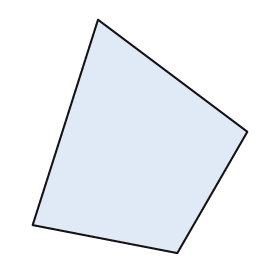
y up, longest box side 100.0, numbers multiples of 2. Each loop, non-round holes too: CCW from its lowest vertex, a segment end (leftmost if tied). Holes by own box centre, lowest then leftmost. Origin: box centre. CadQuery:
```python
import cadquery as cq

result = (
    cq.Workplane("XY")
    .moveTo(16.0, -50.0)
    .lineTo(46.0, 2.0)
    .lineTo(-18.0, 50.0)
    .lineTo(-46.0, -38.0)
    .close()
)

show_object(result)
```